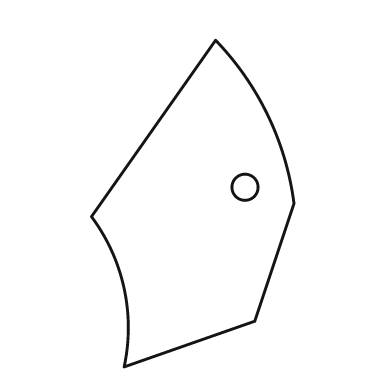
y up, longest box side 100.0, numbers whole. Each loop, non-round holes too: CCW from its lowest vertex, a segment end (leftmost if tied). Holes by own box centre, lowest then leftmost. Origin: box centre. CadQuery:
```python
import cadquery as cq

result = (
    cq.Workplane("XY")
    .moveTo(-21.0, -50.0)
    .lineTo(19.0, -36.0)
    .lineTo(31.0, 0.0)
    .threePointArc((23.0, 27.0), (7.0, 50.0))
    .lineTo(-31.0, -4.0)
    .threePointArc((-21.0, -26.0), (-21.0, -50.0))
    .close()
    .moveTo(16.0, 5.0)
    .circle(4.0)
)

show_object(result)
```